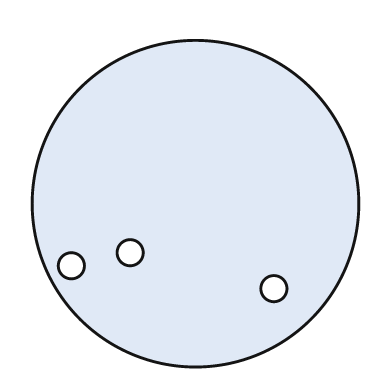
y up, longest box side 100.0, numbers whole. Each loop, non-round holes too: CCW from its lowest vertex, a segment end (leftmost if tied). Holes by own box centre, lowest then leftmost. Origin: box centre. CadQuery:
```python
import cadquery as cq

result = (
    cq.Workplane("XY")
    .moveTo(0.0, 0.0)
    .circle(50.0)
    .moveTo(24.0, -26.0)
    .circle(4.0)
    .moveTo(-38.0, -19.0)
    .circle(4.0)
    .moveTo(-20.0, -15.0)
    .circle(4.0)
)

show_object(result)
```